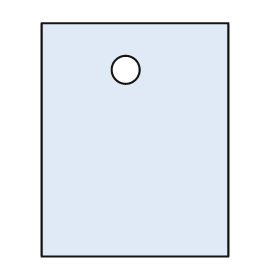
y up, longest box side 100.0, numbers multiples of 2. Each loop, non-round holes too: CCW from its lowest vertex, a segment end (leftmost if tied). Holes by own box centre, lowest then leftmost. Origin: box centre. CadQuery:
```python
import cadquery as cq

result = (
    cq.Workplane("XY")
    .moveTo(-40.0, -50.0)
    .lineTo(40.0, -50.0)
    .lineTo(40.0, 50.0)
    .lineTo(-40.0, 50.0)
    .close()
    .moveTo(-4.0, 30.0)
    .circle(6.0)
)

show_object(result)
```